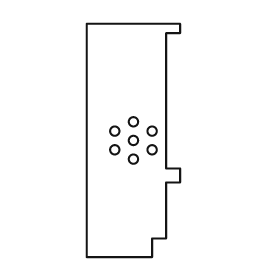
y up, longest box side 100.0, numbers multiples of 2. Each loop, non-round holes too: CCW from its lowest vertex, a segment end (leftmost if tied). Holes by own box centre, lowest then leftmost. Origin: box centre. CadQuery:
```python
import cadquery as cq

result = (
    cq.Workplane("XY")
    .moveTo(-20.0, -50.0)
    .lineTo(8.0, -50.0)
    .lineTo(8.0, -42.0)
    .lineTo(14.0, -42.0)
    .lineTo(14.0, -18.0)
    .lineTo(20.0, -18.0)
    .lineTo(20.0, -12.0)
    .lineTo(14.0, -12.0)
    .lineTo(14.0, 46.0)
    .lineTo(20.0, 46.0)
    .lineTo(20.0, 50.0)
    .lineTo(-20.0, 50.0)
    .close()
    .moveTo(0.0, -8.0)
    .circle(2.0)
    .moveTo(-8.0, -4.0)
    .circle(2.0)
    .moveTo(8.0, -4.0)
    .circle(2.0)
    .moveTo(0.0, 0.0)
    .circle(2.0)
    .moveTo(-8.0, 4.0)
    .circle(2.0)
    .moveTo(8.0, 4.0)
    .circle(2.0)
    .moveTo(0.0, 8.0)
    .circle(2.0)
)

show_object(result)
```